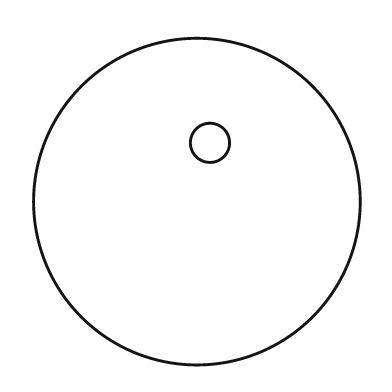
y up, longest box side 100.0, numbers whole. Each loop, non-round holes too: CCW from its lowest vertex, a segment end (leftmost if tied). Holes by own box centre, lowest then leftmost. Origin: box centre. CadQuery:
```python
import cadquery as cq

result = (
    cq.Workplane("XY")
    .moveTo(0.0, 0.0)
    .circle(50.0)
    .moveTo(4.0, 18.0)
    .circle(6.0)
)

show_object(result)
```